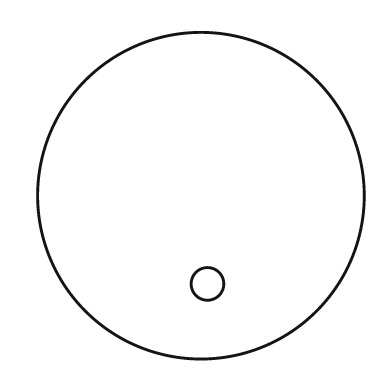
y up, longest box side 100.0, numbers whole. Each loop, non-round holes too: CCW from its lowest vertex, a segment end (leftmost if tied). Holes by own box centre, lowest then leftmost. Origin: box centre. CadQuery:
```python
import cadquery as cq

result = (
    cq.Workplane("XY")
    .moveTo(0.0, 0.0)
    .circle(50.0)
    .moveTo(2.0, -27.0)
    .circle(5.0)
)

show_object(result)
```